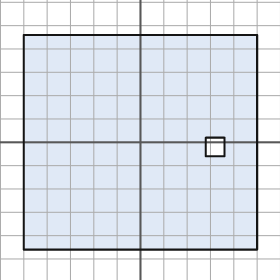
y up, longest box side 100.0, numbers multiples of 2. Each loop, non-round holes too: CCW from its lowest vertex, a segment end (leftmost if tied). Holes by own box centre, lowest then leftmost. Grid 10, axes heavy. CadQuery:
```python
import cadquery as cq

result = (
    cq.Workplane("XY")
    .moveTo(-50.0, -46.0)
    .lineTo(50.0, -46.0)
    .lineTo(50.0, 46.0)
    .lineTo(-50.0, 46.0)
    .close()
    .moveTo(28.0, -6.0)
    .lineTo(36.0, -6.0)
    .lineTo(36.0, 2.0)
    .lineTo(28.0, 2.0)
    .close()
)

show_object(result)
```